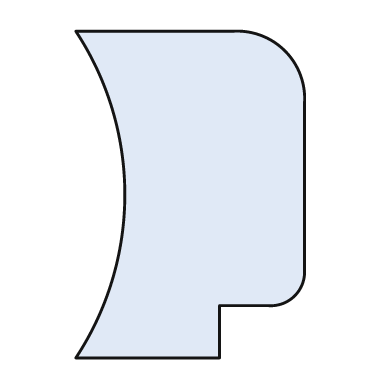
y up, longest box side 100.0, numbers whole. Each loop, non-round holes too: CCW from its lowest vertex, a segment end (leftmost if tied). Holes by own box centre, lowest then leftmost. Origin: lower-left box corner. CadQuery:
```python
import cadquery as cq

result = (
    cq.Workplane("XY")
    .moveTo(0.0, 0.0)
    .lineTo(44.0, 0.0)
    .lineTo(44.0, 16.0)
    .lineTo(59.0, 16.0)
    .threePointArc((67.0, 19.0), (70.0, 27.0))
    .lineTo(70.0, 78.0)
    .threePointArc((64.0, 94.0), (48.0, 100.0))
    .lineTo(0.0, 100.0)
    .threePointArc((15.0, 50.0), (0.0, 0.0))
    .close()
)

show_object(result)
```